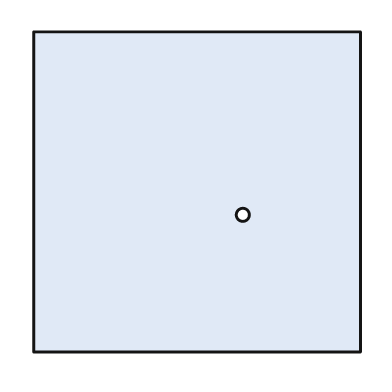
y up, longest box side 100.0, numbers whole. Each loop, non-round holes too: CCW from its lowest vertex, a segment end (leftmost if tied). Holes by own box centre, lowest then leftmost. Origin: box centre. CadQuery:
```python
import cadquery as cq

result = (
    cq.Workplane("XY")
    .moveTo(-50.0, -49.0)
    .lineTo(50.0, -49.0)
    .lineTo(50.0, 49.0)
    .lineTo(-50.0, 49.0)
    .close()
    .moveTo(14.0, -7.0)
    .circle(2.0)
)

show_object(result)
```